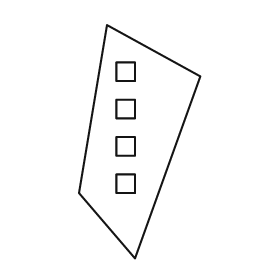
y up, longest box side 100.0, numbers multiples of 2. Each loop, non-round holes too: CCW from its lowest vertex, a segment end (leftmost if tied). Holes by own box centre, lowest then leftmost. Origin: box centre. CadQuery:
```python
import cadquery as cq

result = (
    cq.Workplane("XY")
    .moveTo(-2.0, -50.0)
    .lineTo(26.0, 28.0)
    .lineTo(-14.0, 50.0)
    .lineTo(-26.0, -22.0)
    .close()
    .moveTo(-10.0, -22.0)
    .lineTo(-2.0, -22.0)
    .lineTo(-2.0, -14.0)
    .lineTo(-10.0, -14.0)
    .close()
    .moveTo(-10.0, -6.0)
    .lineTo(-2.0, -6.0)
    .lineTo(-2.0, 2.0)
    .lineTo(-10.0, 2.0)
    .close()
    .moveTo(-10.0, 10.0)
    .lineTo(-2.0, 10.0)
    .lineTo(-2.0, 18.0)
    .lineTo(-10.0, 18.0)
    .close()
    .moveTo(-10.0, 26.0)
    .lineTo(-2.0, 26.0)
    .lineTo(-2.0, 34.0)
    .lineTo(-10.0, 34.0)
    .close()
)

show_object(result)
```